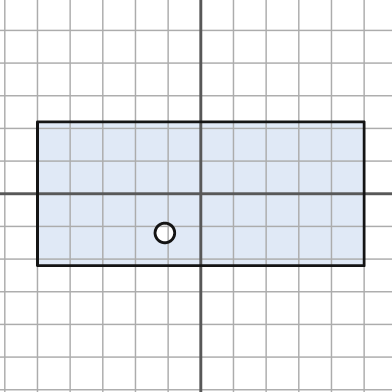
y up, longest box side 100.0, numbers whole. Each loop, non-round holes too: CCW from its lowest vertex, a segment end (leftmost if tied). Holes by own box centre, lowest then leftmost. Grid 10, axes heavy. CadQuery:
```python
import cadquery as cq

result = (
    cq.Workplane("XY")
    .moveTo(-50.0, -22.0)
    .lineTo(50.0, -22.0)
    .lineTo(50.0, 22.0)
    .lineTo(-50.0, 22.0)
    .close()
    .moveTo(-11.0, -12.0)
    .circle(3.0)
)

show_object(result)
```